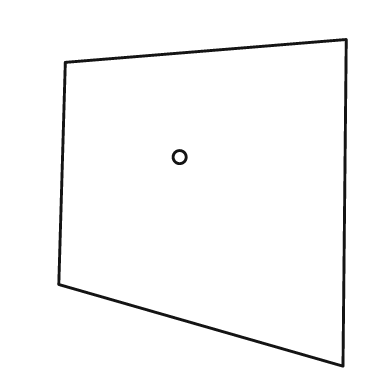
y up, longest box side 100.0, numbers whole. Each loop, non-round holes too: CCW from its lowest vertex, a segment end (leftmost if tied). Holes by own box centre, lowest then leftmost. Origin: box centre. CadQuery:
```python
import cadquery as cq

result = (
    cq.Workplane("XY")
    .moveTo(43.0, -50.0)
    .lineTo(44.0, 50.0)
    .lineTo(-42.0, 43.0)
    .lineTo(-44.0, -25.0)
    .close()
    .moveTo(-7.0, 14.0)
    .circle(2.0)
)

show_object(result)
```